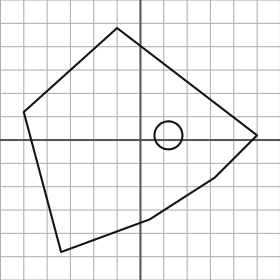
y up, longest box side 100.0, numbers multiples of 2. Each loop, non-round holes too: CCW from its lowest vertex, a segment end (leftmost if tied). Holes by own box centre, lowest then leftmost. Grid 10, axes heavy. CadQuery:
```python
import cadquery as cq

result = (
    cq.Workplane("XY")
    .moveTo(-34.0, -48.0)
    .lineTo(4.0, -34.0)
    .lineTo(32.0, -16.0)
    .lineTo(50.0, 2.0)
    .lineTo(-10.0, 48.0)
    .lineTo(-50.0, 12.0)
    .close()
    .moveTo(12.0, 2.0)
    .circle(6.0)
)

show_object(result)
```